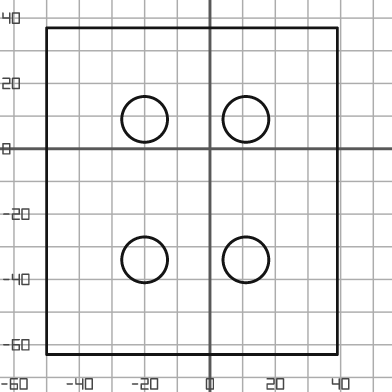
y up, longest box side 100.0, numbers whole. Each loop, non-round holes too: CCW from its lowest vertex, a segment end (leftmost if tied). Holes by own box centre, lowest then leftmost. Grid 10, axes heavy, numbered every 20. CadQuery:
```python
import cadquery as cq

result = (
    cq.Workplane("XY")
    .moveTo(-50.0, -63.0)
    .lineTo(39.0, -63.0)
    .lineTo(39.0, 37.0)
    .lineTo(-50.0, 37.0)
    .close()
    .moveTo(-20.0, -34.0)
    .circle(7.0)
    .moveTo(11.0, -34.0)
    .circle(7.0)
    .moveTo(-20.0, 9.0)
    .circle(7.0)
    .moveTo(11.0, 9.0)
    .circle(7.0)
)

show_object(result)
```